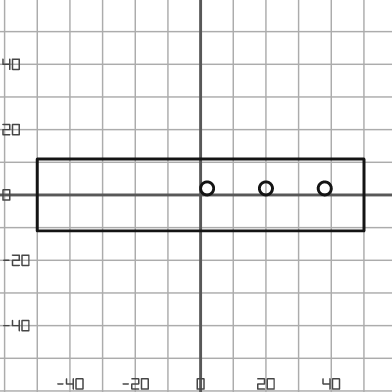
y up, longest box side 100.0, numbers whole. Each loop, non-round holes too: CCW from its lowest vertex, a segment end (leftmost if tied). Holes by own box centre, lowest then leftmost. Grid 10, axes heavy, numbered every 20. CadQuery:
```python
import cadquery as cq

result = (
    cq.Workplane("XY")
    .moveTo(-50.0, -11.0)
    .lineTo(50.0, -11.0)
    .lineTo(50.0, 11.0)
    .lineTo(-50.0, 11.0)
    .close()
    .moveTo(2.0, 2.0)
    .circle(2.0)
    .moveTo(20.0, 2.0)
    .circle(2.0)
    .moveTo(38.0, 2.0)
    .circle(2.0)
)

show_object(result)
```